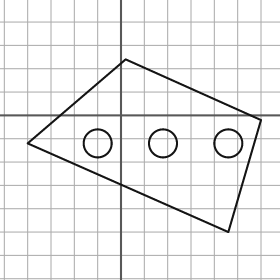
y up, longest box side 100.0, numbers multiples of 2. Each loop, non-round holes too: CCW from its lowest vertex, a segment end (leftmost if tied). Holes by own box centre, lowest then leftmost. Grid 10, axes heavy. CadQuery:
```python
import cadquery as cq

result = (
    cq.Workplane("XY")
    .moveTo(46.0, -50.0)
    .lineTo(60.0, -2.0)
    .lineTo(2.0, 24.0)
    .lineTo(-40.0, -12.0)
    .close()
    .moveTo(-10.0, -12.0)
    .circle(6.0)
    .moveTo(18.0, -12.0)
    .circle(6.0)
    .moveTo(46.0, -12.0)
    .circle(6.0)
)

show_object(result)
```